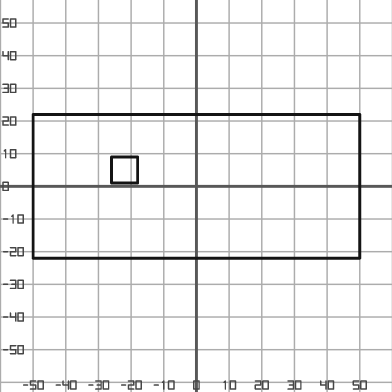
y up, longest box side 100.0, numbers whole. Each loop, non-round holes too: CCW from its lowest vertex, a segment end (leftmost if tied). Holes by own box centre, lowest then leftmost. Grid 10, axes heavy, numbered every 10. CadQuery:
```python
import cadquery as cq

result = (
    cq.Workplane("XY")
    .moveTo(-50.0, -22.0)
    .lineTo(50.0, -22.0)
    .lineTo(50.0, 22.0)
    .lineTo(-50.0, 22.0)
    .close()
    .moveTo(-26.0, 1.0)
    .lineTo(-18.0, 1.0)
    .lineTo(-18.0, 9.0)
    .lineTo(-26.0, 9.0)
    .close()
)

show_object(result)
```